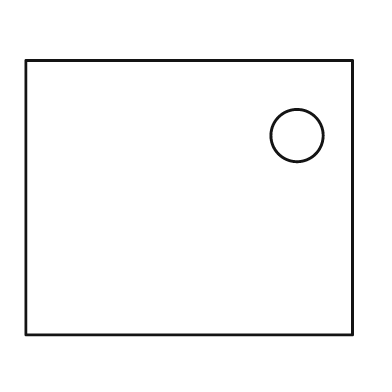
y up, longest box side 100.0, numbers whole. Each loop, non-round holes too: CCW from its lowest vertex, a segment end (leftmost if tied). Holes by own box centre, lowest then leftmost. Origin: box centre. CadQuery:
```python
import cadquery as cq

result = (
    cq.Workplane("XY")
    .moveTo(-50.0, -42.0)
    .lineTo(50.0, -42.0)
    .lineTo(50.0, 42.0)
    .lineTo(-50.0, 42.0)
    .close()
    .moveTo(33.0, 19.0)
    .circle(8.0)
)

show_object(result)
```